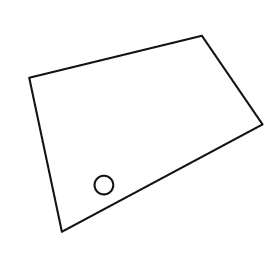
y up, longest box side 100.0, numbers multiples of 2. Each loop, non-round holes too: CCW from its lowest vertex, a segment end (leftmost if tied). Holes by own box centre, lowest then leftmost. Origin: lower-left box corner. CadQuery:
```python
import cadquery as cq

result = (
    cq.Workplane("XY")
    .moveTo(14.0, 0.0)
    .lineTo(100.0, 46.0)
    .lineTo(74.0, 84.0)
    .lineTo(0.0, 66.0)
    .close()
    .moveTo(32.0, 20.0)
    .circle(4.0)
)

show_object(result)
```